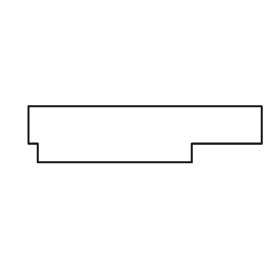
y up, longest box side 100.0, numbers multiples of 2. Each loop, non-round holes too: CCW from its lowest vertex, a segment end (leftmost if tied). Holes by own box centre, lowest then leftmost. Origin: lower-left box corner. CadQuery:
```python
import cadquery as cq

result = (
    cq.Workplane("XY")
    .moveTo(4.0, 0.0)
    .lineTo(70.0, 0.0)
    .lineTo(70.0, 8.0)
    .lineTo(100.0, 8.0)
    .lineTo(100.0, 24.0)
    .lineTo(0.0, 24.0)
    .lineTo(0.0, 8.0)
    .lineTo(4.0, 8.0)
    .close()
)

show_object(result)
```